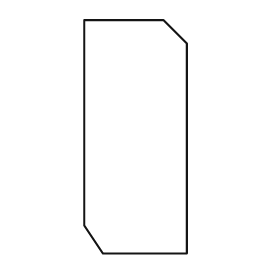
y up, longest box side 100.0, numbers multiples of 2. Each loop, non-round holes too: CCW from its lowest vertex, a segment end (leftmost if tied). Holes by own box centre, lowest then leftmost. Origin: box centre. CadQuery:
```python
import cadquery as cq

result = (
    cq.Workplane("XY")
    .moveTo(-14.0, -50.0)
    .lineTo(22.0, -50.0)
    .lineTo(22.0, 40.0)
    .lineTo(12.0, 50.0)
    .lineTo(-22.0, 50.0)
    .lineTo(-22.0, -38.0)
    .close()
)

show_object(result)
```